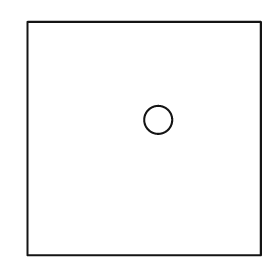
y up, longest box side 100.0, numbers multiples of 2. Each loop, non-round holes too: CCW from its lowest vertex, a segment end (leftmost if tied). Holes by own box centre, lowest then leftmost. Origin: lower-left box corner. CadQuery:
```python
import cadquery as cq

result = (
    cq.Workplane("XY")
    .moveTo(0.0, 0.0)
    .lineTo(100.0, 0.0)
    .lineTo(100.0, 100.0)
    .lineTo(0.0, 100.0)
    .close()
    .moveTo(56.0, 58.0)
    .circle(6.0)
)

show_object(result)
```